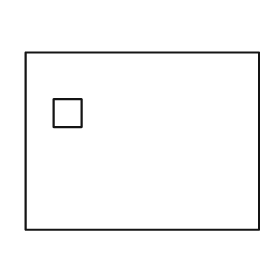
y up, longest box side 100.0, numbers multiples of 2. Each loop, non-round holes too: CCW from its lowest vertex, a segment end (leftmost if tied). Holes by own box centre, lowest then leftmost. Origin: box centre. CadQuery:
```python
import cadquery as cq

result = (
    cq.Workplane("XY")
    .moveTo(-50.0, -38.0)
    .lineTo(50.0, -38.0)
    .lineTo(50.0, 38.0)
    .lineTo(-50.0, 38.0)
    .close()
    .moveTo(-38.0, 6.0)
    .lineTo(-26.0, 6.0)
    .lineTo(-26.0, 18.0)
    .lineTo(-38.0, 18.0)
    .close()
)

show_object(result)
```